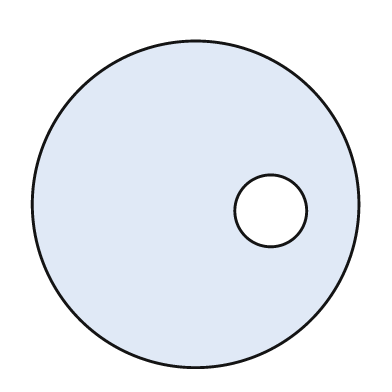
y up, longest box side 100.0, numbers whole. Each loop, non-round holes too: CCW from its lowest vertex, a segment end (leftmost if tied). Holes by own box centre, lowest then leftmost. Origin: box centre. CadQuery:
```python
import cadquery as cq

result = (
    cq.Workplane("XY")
    .moveTo(0.0, 0.0)
    .circle(50.0)
    .moveTo(23.0, -2.0)
    .circle(11.0)
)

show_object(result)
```